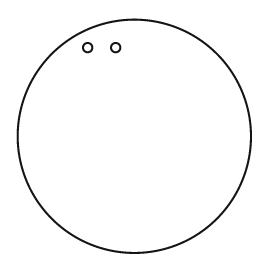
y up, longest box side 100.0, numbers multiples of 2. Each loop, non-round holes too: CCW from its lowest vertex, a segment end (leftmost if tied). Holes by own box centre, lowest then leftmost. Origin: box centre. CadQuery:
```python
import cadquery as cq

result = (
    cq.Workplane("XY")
    .moveTo(0.0, 0.0)
    .circle(50.0)
    .moveTo(-20.0, 38.0)
    .circle(2.0)
    .moveTo(-8.0, 38.0)
    .circle(2.0)
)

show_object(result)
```